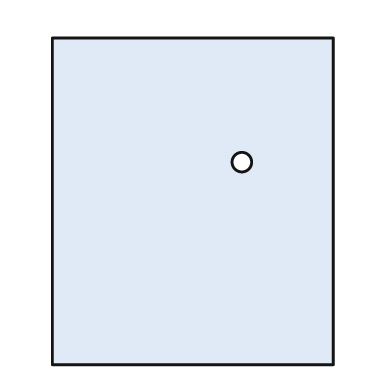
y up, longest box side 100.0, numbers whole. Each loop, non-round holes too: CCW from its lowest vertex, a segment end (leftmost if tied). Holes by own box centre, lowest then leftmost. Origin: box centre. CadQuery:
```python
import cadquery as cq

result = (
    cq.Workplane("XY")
    .moveTo(-43.0, -50.0)
    .lineTo(43.0, -50.0)
    .lineTo(43.0, 50.0)
    .lineTo(-43.0, 50.0)
    .close()
    .moveTo(15.0, 12.0)
    .circle(3.0)
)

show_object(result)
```